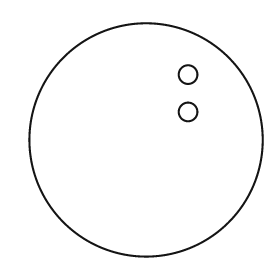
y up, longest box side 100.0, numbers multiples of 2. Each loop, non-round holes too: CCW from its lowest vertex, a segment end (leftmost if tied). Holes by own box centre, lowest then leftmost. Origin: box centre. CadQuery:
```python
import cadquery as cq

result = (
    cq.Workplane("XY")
    .moveTo(0.0, 0.0)
    .circle(50.0)
    .moveTo(18.0, 12.0)
    .circle(4.0)
    .moveTo(18.0, 28.0)
    .circle(4.0)
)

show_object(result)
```